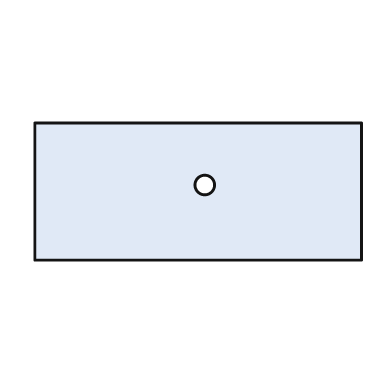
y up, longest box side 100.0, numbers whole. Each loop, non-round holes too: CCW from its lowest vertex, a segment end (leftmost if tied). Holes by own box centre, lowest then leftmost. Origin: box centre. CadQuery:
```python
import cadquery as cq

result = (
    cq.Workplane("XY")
    .moveTo(-50.0, -21.0)
    .lineTo(50.0, -21.0)
    .lineTo(50.0, 21.0)
    .lineTo(-50.0, 21.0)
    .close()
    .moveTo(2.0, 2.0)
    .circle(3.0)
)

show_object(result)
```